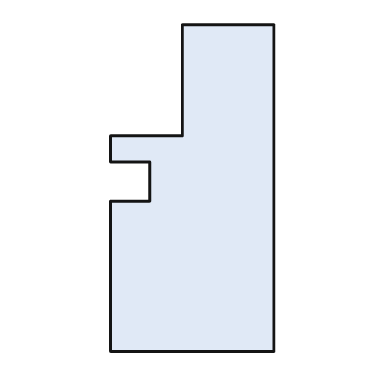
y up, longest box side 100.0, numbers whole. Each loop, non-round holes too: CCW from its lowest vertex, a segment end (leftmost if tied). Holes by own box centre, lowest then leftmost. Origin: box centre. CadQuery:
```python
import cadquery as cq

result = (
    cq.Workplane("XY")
    .moveTo(-25.0, -50.0)
    .lineTo(25.0, -50.0)
    .lineTo(25.0, 50.0)
    .lineTo(-3.0, 50.0)
    .lineTo(-3.0, 16.0)
    .lineTo(-25.0, 16.0)
    .lineTo(-25.0, 8.0)
    .lineTo(-13.0, 8.0)
    .lineTo(-13.0, -4.0)
    .lineTo(-25.0, -4.0)
    .close()
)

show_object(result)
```